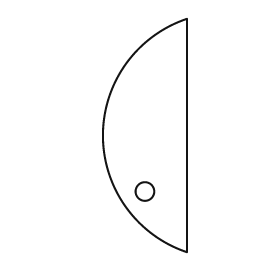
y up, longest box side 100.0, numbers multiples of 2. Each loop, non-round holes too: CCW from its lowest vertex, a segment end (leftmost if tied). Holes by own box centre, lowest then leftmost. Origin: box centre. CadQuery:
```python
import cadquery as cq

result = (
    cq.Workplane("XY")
    .moveTo(18.0, -50.0)
    .lineTo(18.0, 50.0)
    .threePointArc((-18.0, 0.0), (18.0, -50.0))
    .close()
    .moveTo(0.0, -24.0)
    .circle(4.0)
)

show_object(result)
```